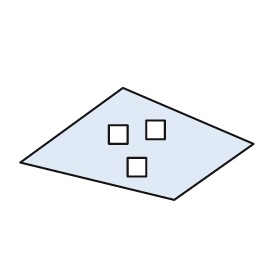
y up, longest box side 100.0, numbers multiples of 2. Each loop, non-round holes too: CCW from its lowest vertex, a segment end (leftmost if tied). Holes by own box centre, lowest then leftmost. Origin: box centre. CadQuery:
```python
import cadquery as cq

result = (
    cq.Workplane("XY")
    .moveTo(16.0, -24.0)
    .lineTo(50.0, 0.0)
    .lineTo(-6.0, 24.0)
    .lineTo(-50.0, -8.0)
    .close()
    .moveTo(-4.0, -14.0)
    .lineTo(4.0, -14.0)
    .lineTo(4.0, -6.0)
    .lineTo(-4.0, -6.0)
    .close()
    .moveTo(-12.0, 0.0)
    .lineTo(-4.0, 0.0)
    .lineTo(-4.0, 8.0)
    .lineTo(-12.0, 8.0)
    .close()
    .moveTo(4.0, 2.0)
    .lineTo(12.0, 2.0)
    .lineTo(12.0, 10.0)
    .lineTo(4.0, 10.0)
    .close()
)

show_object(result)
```